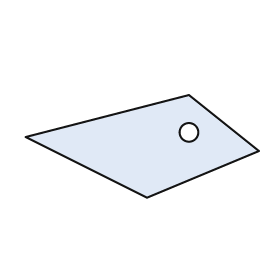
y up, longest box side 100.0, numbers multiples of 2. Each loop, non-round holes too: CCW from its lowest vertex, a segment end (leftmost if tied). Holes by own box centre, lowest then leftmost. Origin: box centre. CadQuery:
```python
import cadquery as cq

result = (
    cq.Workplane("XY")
    .moveTo(2.0, -22.0)
    .lineTo(50.0, -2.0)
    .lineTo(20.0, 22.0)
    .lineTo(-50.0, 4.0)
    .close()
    .moveTo(20.0, 6.0)
    .circle(4.0)
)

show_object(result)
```